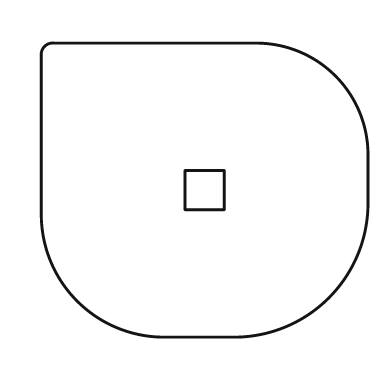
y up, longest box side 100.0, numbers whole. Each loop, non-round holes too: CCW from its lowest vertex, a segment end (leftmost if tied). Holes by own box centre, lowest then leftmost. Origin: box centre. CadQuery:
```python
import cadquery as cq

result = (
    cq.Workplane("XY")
    .moveTo(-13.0, -45.0)
    .lineTo(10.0, -45.0)
    .threePointArc((38.0, -33.0), (50.0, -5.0))
    .lineTo(50.0, 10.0)
    .threePointArc((40.0, 35.0), (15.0, 45.0))
    .lineTo(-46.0, 45.0)
    .threePointArc((-49.0, 44.0), (-50.0, 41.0))
    .lineTo(-50.0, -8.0)
    .threePointArc((-39.0, -34.0), (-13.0, -45.0))
    .close()
    .moveTo(-6.0, -6.0)
    .lineTo(6.0, -6.0)
    .lineTo(6.0, 6.0)
    .lineTo(-6.0, 6.0)
    .close()
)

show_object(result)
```